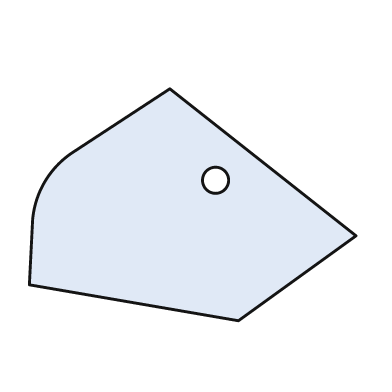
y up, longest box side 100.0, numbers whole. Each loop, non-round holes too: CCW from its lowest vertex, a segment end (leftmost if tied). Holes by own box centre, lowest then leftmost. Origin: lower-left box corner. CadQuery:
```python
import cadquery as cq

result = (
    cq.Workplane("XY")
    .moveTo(64.0, 0.0)
    .lineTo(100.0, 26.0)
    .lineTo(43.0, 71.0)
    .lineTo(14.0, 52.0)
    .threePointArc((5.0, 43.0), (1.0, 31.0))
    .lineTo(0.0, 11.0)
    .close()
    .moveTo(57.0, 43.0)
    .circle(4.0)
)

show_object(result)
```